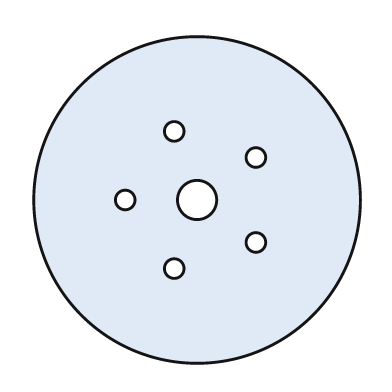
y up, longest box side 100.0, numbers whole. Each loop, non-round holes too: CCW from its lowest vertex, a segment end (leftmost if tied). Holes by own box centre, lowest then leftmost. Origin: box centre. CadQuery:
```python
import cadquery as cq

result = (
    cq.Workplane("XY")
    .moveTo(0.0, 0.0)
    .circle(50.0)
    .moveTo(-7.0, -21.0)
    .circle(3.0)
    .moveTo(18.0, -13.0)
    .circle(3.0)
    .moveTo(-22.0, 0.0)
    .circle(3.0)
    .moveTo(0.0, 0.0)
    .circle(6.0)
    .moveTo(18.0, 13.0)
    .circle(3.0)
    .moveTo(-7.0, 21.0)
    .circle(3.0)
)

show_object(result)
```